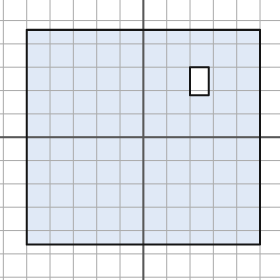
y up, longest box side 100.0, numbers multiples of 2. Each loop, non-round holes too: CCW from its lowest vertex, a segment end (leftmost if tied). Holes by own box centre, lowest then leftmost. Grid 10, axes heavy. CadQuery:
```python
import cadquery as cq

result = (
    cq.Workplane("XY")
    .moveTo(-50.0, -46.0)
    .lineTo(50.0, -46.0)
    .lineTo(50.0, 46.0)
    .lineTo(-50.0, 46.0)
    .close()
    .moveTo(20.0, 18.0)
    .lineTo(28.0, 18.0)
    .lineTo(28.0, 30.0)
    .lineTo(20.0, 30.0)
    .close()
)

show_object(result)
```